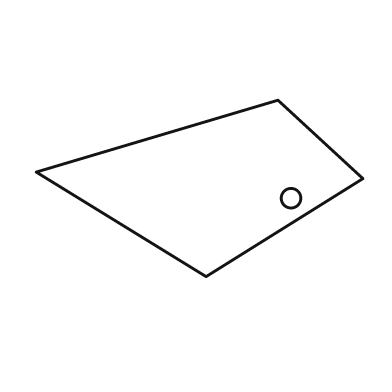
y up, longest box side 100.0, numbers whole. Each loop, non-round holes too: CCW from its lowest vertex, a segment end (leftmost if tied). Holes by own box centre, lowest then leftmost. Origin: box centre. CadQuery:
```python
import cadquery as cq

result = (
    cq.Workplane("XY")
    .moveTo(2.0, -27.0)
    .lineTo(50.0, 3.0)
    .lineTo(24.0, 27.0)
    .lineTo(-50.0, 5.0)
    .close()
    .moveTo(28.0, -3.0)
    .circle(3.0)
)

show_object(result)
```